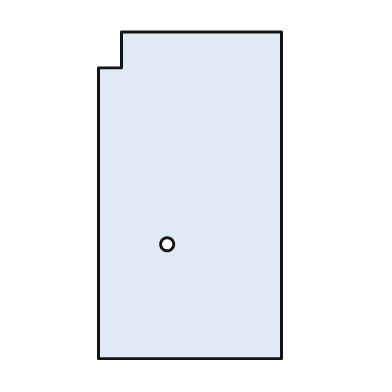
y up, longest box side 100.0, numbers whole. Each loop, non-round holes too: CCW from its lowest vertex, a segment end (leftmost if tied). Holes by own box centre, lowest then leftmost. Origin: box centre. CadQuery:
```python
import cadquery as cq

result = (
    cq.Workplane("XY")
    .moveTo(-28.0, -50.0)
    .lineTo(28.0, -50.0)
    .lineTo(28.0, 50.0)
    .lineTo(-21.0, 50.0)
    .lineTo(-21.0, 39.0)
    .lineTo(-28.0, 39.0)
    .close()
    .moveTo(-7.0, -15.0)
    .circle(2.0)
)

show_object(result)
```